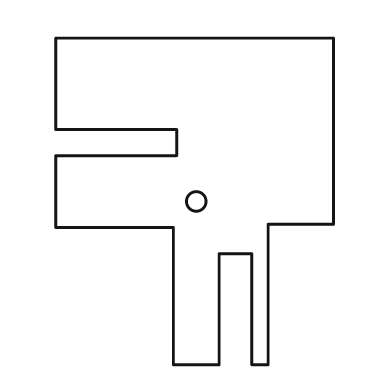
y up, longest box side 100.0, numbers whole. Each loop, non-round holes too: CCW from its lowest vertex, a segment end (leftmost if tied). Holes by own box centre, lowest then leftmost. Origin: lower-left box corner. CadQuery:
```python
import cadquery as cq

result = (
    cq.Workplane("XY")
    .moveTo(36.0, 0.0)
    .lineTo(50.0, 0.0)
    .lineTo(50.0, 34.0)
    .lineTo(60.0, 34.0)
    .lineTo(60.0, 0.0)
    .lineTo(65.0, 0.0)
    .lineTo(65.0, 43.0)
    .lineTo(85.0, 43.0)
    .lineTo(85.0, 100.0)
    .lineTo(0.0, 100.0)
    .lineTo(0.0, 72.0)
    .lineTo(37.0, 72.0)
    .lineTo(37.0, 64.0)
    .lineTo(0.0, 64.0)
    .lineTo(0.0, 42.0)
    .lineTo(36.0, 42.0)
    .close()
    .moveTo(43.0, 50.0)
    .circle(3.0)
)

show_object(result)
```